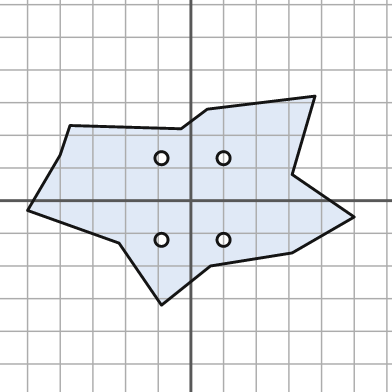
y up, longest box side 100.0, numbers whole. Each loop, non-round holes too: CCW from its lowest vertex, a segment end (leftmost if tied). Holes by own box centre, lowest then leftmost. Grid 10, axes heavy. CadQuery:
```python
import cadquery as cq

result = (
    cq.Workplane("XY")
    .moveTo(-9.0, -32.0)
    .lineTo(6.0, -20.0)
    .lineTo(31.0, -16.0)
    .lineTo(50.0, -5.0)
    .lineTo(31.0, 8.0)
    .lineTo(38.0, 32.0)
    .lineTo(5.0, 28.0)
    .lineTo(-3.0, 22.0)
    .lineTo(-37.0, 23.0)
    .lineTo(-40.0, 14.0)
    .lineTo(-50.0, -3.0)
    .lineTo(-22.0, -13.0)
    .close()
    .moveTo(-9.0, -12.0)
    .circle(2.0)
    .moveTo(10.0, -12.0)
    .circle(2.0)
    .moveTo(-9.0, 13.0)
    .circle(2.0)
    .moveTo(10.0, 13.0)
    .circle(2.0)
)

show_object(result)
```